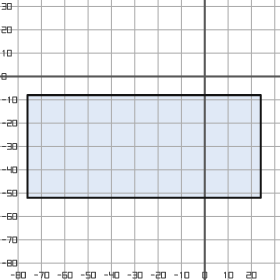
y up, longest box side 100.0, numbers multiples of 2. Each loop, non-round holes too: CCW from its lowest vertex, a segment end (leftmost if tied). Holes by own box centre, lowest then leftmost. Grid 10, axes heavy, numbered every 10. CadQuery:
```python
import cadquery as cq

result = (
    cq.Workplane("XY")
    .moveTo(-76.0, -52.0)
    .lineTo(24.0, -52.0)
    .lineTo(24.0, -8.0)
    .lineTo(-76.0, -8.0)
    .close()
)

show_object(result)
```